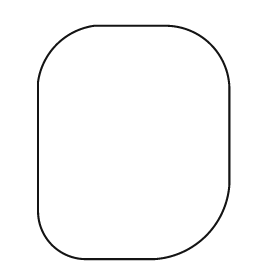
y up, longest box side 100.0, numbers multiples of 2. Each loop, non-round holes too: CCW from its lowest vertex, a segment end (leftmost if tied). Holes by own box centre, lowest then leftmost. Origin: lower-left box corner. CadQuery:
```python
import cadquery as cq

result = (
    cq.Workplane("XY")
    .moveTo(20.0, 0.0)
    .lineTo(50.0, 0.0)
    .threePointArc((72.0, 10.0), (82.0, 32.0))
    .lineTo(82.0, 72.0)
    .threePointArc((74.0, 92.0), (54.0, 100.0))
    .lineTo(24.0, 100.0)
    .threePointArc((8.0, 92.0), (0.0, 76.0))
    .lineTo(0.0, 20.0)
    .threePointArc((6.0, 6.0), (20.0, 0.0))
    .close()
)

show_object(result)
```